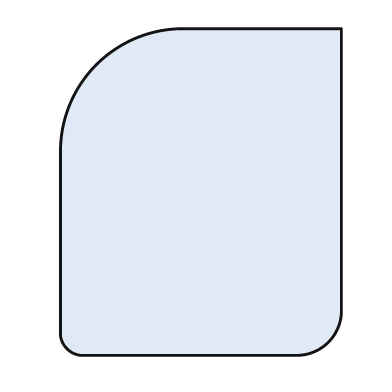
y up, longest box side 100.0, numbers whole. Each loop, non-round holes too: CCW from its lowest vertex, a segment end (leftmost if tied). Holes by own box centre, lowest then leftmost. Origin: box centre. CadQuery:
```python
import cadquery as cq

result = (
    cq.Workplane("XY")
    .moveTo(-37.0, -50.0)
    .lineTo(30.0, -50.0)
    .threePointArc((39.0, -46.0), (43.0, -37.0))
    .lineTo(43.0, 50.0)
    .lineTo(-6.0, 50.0)
    .threePointArc((-32.0, 39.0), (-43.0, 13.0))
    .lineTo(-43.0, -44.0)
    .threePointArc((-41.0, -48.0), (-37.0, -50.0))
    .close()
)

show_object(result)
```